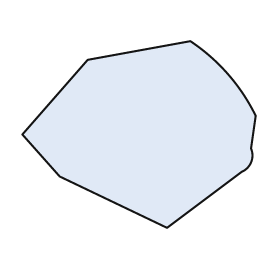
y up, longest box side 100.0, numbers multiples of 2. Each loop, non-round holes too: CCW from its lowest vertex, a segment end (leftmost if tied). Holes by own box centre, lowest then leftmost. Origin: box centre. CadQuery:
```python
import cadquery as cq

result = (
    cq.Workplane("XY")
    .moveTo(12.0, -40.0)
    .lineTo(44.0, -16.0)
    .threePointArc((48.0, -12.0), (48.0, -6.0))
    .lineTo(50.0, 8.0)
    .threePointArc((38.0, 26.0), (22.0, 40.0))
    .lineTo(-22.0, 32.0)
    .lineTo(-50.0, 0.0)
    .lineTo(-34.0, -18.0)
    .close()
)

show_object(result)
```